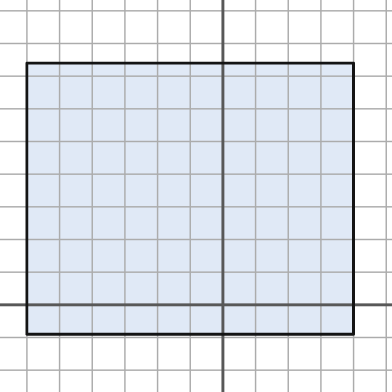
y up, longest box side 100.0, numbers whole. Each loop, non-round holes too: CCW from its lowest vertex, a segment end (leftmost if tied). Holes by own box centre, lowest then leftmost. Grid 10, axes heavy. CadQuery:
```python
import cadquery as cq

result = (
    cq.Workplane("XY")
    .moveTo(-60.0, -9.0)
    .lineTo(40.0, -9.0)
    .lineTo(40.0, 74.0)
    .lineTo(-60.0, 74.0)
    .close()
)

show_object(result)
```